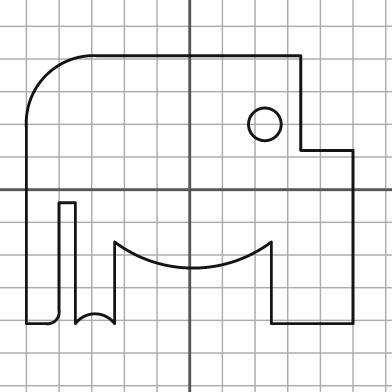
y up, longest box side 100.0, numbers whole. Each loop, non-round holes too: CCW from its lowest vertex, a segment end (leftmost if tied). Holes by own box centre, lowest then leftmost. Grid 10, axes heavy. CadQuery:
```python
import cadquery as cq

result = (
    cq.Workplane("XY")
    .moveTo(-50.0, -41.0)
    .lineTo(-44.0, -41.0)
    .threePointArc((-41.0, -40.0), (-40.0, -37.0))
    .lineTo(-40.0, -4.0)
    .lineTo(-35.0, -4.0)
    .lineTo(-35.0, -41.0)
    .threePointArc((-29.0, -38.0), (-23.0, -41.0))
    .lineTo(-23.0, -16.0)
    .threePointArc((1.0, -24.0), (25.0, -16.0))
    .lineTo(25.0, -41.0)
    .lineTo(50.0, -41.0)
    .lineTo(50.0, 12.0)
    .lineTo(34.0, 12.0)
    .lineTo(34.0, 41.0)
    .lineTo(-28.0, 41.0)
    .threePointArc((-44.0, 35.0), (-50.0, 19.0))
    .close()
    .moveTo(23.0, 20.0)
    .circle(5.0)
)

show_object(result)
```